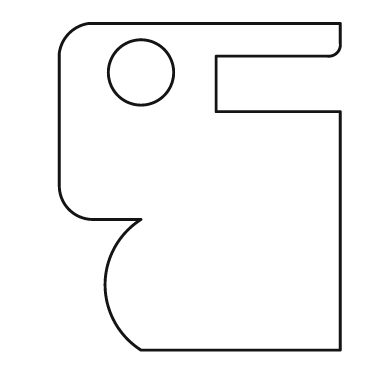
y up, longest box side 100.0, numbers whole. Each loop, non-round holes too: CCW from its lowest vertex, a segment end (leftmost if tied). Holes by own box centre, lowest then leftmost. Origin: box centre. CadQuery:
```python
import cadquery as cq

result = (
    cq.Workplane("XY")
    .moveTo(-18.0, -50.0)
    .lineTo(43.0, -50.0)
    .lineTo(43.0, 23.0)
    .lineTo(5.0, 23.0)
    .lineTo(5.0, 40.0)
    .lineTo(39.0, 40.0)
    .threePointArc((42.0, 41.0), (43.0, 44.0))
    .lineTo(43.0, 50.0)
    .lineTo(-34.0, 50.0)
    .threePointArc((-40.0, 47.0), (-43.0, 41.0))
    .lineTo(-43.0, 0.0)
    .threePointArc((-40.0, -7.0), (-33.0, -10.0))
    .lineTo(-18.0, -10.0)
    .threePointArc((-29.0, -30.0), (-18.0, -50.0))
    .close()
    .moveTo(-18.0, 35.0)
    .circle(10.0)
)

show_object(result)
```